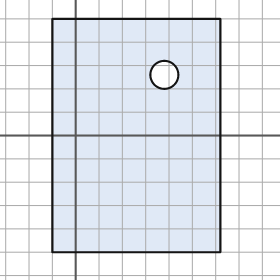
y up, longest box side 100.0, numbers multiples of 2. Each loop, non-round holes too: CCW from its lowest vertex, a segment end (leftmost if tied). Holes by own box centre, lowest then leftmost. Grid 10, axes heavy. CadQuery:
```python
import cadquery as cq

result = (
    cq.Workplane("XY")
    .moveTo(-10.0, -50.0)
    .lineTo(62.0, -50.0)
    .lineTo(62.0, 50.0)
    .lineTo(-10.0, 50.0)
    .close()
    .moveTo(38.0, 26.0)
    .circle(6.0)
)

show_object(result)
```